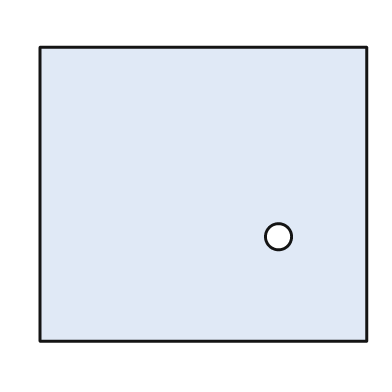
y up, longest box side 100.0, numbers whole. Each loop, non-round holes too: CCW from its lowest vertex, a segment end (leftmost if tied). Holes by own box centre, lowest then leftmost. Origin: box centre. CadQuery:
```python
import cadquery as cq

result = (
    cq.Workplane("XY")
    .moveTo(-50.0, -45.0)
    .lineTo(50.0, -45.0)
    .lineTo(50.0, 45.0)
    .lineTo(-50.0, 45.0)
    .close()
    .moveTo(23.0, -13.0)
    .circle(4.0)
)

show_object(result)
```